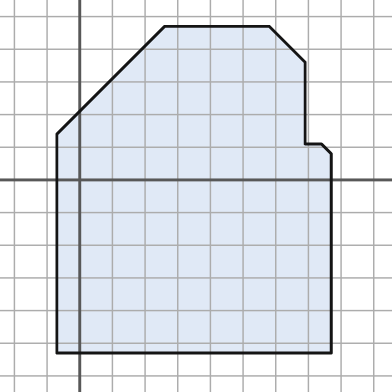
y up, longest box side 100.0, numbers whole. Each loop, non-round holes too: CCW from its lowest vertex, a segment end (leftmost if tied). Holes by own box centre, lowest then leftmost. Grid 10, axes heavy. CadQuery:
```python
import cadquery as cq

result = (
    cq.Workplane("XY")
    .moveTo(-7.0, -53.0)
    .lineTo(77.0, -53.0)
    .lineTo(77.0, 8.0)
    .lineTo(74.0, 11.0)
    .lineTo(69.0, 11.0)
    .lineTo(69.0, 36.0)
    .lineTo(58.0, 47.0)
    .lineTo(26.0, 47.0)
    .lineTo(-7.0, 14.0)
    .close()
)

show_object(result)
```